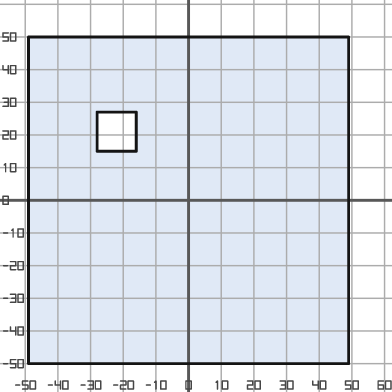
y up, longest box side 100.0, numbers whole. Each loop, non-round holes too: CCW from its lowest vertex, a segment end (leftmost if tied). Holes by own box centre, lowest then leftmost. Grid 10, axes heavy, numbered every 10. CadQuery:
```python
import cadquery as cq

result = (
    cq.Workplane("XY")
    .moveTo(-49.0, -50.0)
    .lineTo(49.0, -50.0)
    .lineTo(49.0, 50.0)
    .lineTo(-49.0, 50.0)
    .close()
    .moveTo(-28.0, 15.0)
    .lineTo(-16.0, 15.0)
    .lineTo(-16.0, 27.0)
    .lineTo(-28.0, 27.0)
    .close()
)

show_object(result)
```